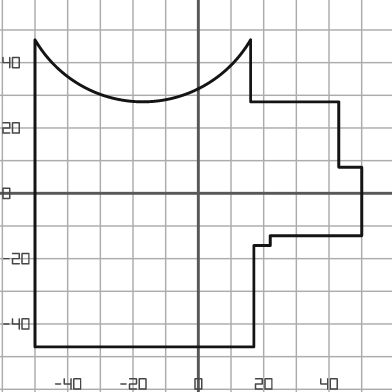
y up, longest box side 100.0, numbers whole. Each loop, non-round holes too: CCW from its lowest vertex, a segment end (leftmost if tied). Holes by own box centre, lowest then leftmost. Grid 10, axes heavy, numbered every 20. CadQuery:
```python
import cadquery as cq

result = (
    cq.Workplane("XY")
    .moveTo(-50.0, -47.0)
    .lineTo(17.0, -47.0)
    .lineTo(17.0, -16.0)
    .lineTo(22.0, -16.0)
    .lineTo(22.0, -13.0)
    .lineTo(50.0, -13.0)
    .lineTo(50.0, 8.0)
    .lineTo(43.0, 8.0)
    .lineTo(43.0, 28.0)
    .lineTo(16.0, 28.0)
    .lineTo(16.0, 47.0)
    .threePointArc((-17.0, 28.0), (-50.0, 47.0))
    .close()
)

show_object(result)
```